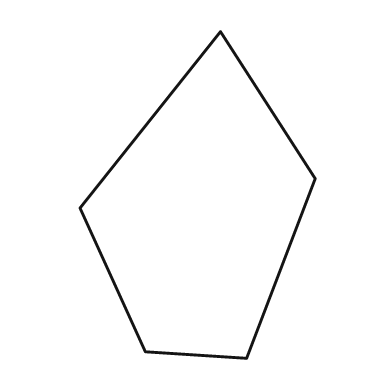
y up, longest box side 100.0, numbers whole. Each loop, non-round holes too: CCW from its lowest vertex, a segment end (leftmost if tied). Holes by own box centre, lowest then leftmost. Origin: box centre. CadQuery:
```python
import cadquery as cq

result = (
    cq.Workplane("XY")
    .moveTo(15.0, -50.0)
    .lineTo(36.0, 5.0)
    .lineTo(7.0, 50.0)
    .lineTo(-36.0, -4.0)
    .lineTo(-16.0, -48.0)
    .close()
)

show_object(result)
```